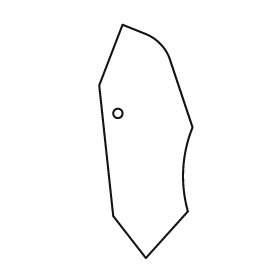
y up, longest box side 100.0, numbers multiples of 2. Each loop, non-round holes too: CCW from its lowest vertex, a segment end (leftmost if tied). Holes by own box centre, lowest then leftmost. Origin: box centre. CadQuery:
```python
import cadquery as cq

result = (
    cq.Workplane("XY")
    .moveTo(0.0, -50.0)
    .lineTo(18.0, -30.0)
    .threePointArc((16.0, -12.0), (20.0, 6.0))
    .lineTo(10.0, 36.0)
    .threePointArc((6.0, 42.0), (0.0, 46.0))
    .lineTo(-10.0, 50.0)
    .lineTo(-20.0, 24.0)
    .lineTo(-14.0, -32.0)
    .close()
    .moveTo(-12.0, 12.0)
    .circle(2.0)
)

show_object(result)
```